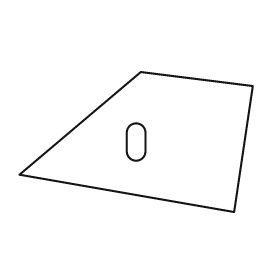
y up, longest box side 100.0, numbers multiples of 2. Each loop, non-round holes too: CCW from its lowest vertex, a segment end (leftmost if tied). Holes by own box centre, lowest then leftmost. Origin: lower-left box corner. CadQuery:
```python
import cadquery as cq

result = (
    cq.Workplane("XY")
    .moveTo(92.0, 0.0)
    .lineTo(100.0, 54.0)
    .lineTo(52.0, 60.0)
    .lineTo(0.0, 16.0)
    .close()
    .moveTo(46.0, 26.0)
    .threePointArc((50.0, 22.0), (54.0, 26.0))
    .lineTo(54.0, 34.0)
    .threePointArc((50.0, 38.0), (46.0, 34.0))
    .close()
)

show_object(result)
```